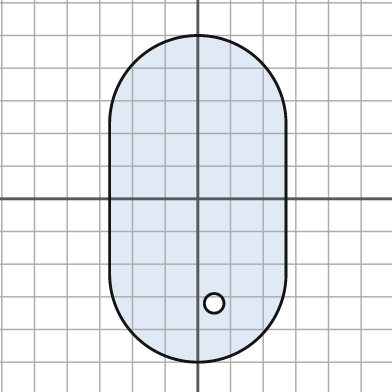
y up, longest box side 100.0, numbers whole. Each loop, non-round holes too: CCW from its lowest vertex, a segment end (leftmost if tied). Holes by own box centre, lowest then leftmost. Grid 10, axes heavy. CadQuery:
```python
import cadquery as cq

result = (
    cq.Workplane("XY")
    .moveTo(-27.0, -23.0)
    .threePointArc((0.0, -50.0), (27.0, -23.0))
    .lineTo(27.0, 23.0)
    .threePointArc((0.0, 50.0), (-27.0, 23.0))
    .close()
    .moveTo(5.0, -32.0)
    .circle(3.0)
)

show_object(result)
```